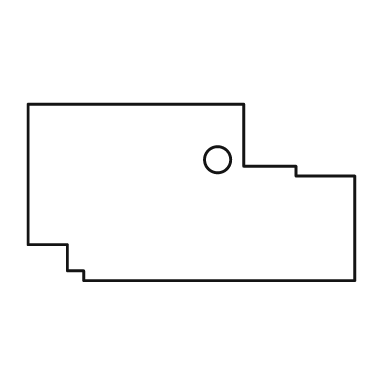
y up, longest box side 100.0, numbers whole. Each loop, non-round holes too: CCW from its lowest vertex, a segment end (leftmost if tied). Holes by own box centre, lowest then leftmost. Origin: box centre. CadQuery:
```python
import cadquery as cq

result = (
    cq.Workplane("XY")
    .moveTo(-33.0, -27.0)
    .lineTo(50.0, -27.0)
    .lineTo(50.0, 5.0)
    .lineTo(32.0, 5.0)
    .lineTo(32.0, 8.0)
    .lineTo(16.0, 8.0)
    .lineTo(16.0, 27.0)
    .lineTo(-50.0, 27.0)
    .lineTo(-50.0, -16.0)
    .lineTo(-38.0, -16.0)
    .lineTo(-38.0, -24.0)
    .lineTo(-33.0, -24.0)
    .close()
    .moveTo(8.0, 10.0)
    .circle(4.0)
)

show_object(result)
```